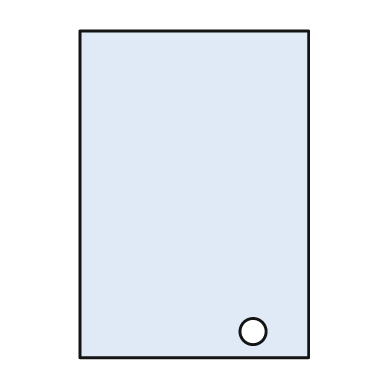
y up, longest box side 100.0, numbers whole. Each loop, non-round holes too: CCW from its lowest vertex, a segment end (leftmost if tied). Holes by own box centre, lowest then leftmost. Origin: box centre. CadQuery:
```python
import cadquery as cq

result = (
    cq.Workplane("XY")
    .moveTo(-35.0, -50.0)
    .lineTo(35.0, -50.0)
    .lineTo(35.0, 50.0)
    .lineTo(-35.0, 50.0)
    .close()
    .moveTo(18.0, -42.0)
    .circle(4.0)
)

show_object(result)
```